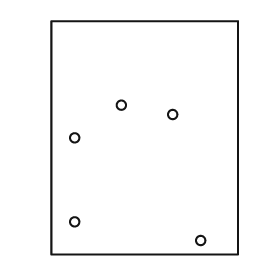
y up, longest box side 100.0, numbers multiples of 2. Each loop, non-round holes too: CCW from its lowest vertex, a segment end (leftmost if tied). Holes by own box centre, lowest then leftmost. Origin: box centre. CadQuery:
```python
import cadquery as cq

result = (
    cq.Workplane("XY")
    .moveTo(-40.0, -50.0)
    .lineTo(40.0, -50.0)
    .lineTo(40.0, 50.0)
    .lineTo(-40.0, 50.0)
    .close()
    .moveTo(24.0, -44.0)
    .circle(2.0)
    .moveTo(-30.0, -36.0)
    .circle(2.0)
    .moveTo(-30.0, 0.0)
    .circle(2.0)
    .moveTo(12.0, 10.0)
    .circle(2.0)
    .moveTo(-10.0, 14.0)
    .circle(2.0)
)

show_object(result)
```